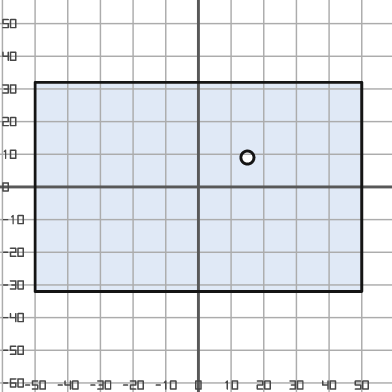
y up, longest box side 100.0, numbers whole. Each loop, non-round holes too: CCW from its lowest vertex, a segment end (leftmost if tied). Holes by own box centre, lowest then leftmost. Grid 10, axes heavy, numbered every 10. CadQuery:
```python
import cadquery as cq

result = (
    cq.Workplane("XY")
    .moveTo(-50.0, -32.0)
    .lineTo(50.0, -32.0)
    .lineTo(50.0, 32.0)
    .lineTo(-50.0, 32.0)
    .close()
    .moveTo(15.0, 9.0)
    .circle(2.0)
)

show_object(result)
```